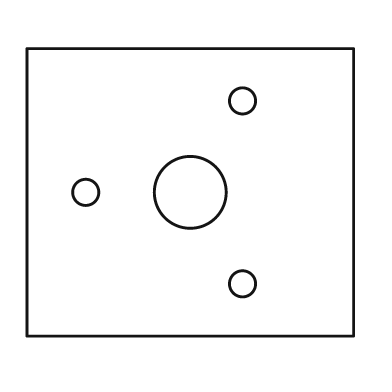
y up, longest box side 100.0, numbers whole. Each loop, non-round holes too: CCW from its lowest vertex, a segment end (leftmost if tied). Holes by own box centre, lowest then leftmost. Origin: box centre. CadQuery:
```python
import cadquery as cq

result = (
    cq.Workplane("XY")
    .moveTo(-50.0, -44.0)
    .lineTo(50.0, -44.0)
    .lineTo(50.0, 44.0)
    .lineTo(-50.0, 44.0)
    .close()
    .moveTo(16.0, -28.0)
    .circle(4.0)
    .moveTo(-32.0, 0.0)
    .circle(4.0)
    .moveTo(0.0, 0.0)
    .circle(11.0)
    .moveTo(16.0, 28.0)
    .circle(4.0)
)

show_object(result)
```